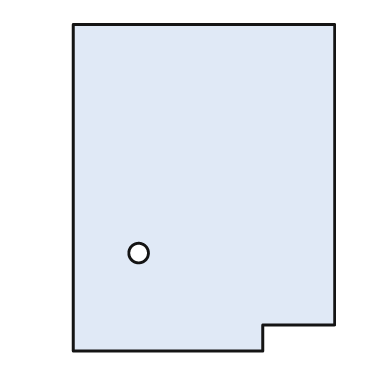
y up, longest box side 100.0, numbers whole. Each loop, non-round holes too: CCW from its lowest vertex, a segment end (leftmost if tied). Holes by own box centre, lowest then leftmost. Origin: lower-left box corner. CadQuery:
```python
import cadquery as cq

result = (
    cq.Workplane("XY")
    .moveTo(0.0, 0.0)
    .lineTo(58.0, 0.0)
    .lineTo(58.0, 8.0)
    .lineTo(80.0, 8.0)
    .lineTo(80.0, 100.0)
    .lineTo(0.0, 100.0)
    .close()
    .moveTo(20.0, 30.0)
    .circle(3.0)
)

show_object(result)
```